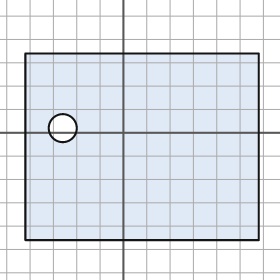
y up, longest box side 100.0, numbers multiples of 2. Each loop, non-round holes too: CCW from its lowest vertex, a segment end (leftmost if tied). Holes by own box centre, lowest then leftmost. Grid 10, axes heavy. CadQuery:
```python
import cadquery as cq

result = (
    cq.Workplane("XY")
    .moveTo(-42.0, -46.0)
    .lineTo(58.0, -46.0)
    .lineTo(58.0, 34.0)
    .lineTo(-42.0, 34.0)
    .close()
    .moveTo(-26.0, 2.0)
    .circle(6.0)
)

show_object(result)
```